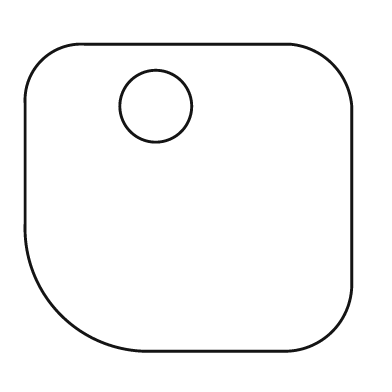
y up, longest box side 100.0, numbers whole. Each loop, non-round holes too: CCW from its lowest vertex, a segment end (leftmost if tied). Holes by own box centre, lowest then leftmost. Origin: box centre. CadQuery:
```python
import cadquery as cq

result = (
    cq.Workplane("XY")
    .moveTo(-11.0, -47.0)
    .lineTo(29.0, -47.0)
    .threePointArc((44.0, -41.0), (50.0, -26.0))
    .lineTo(50.0, 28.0)
    .threePointArc((44.0, 41.0), (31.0, 47.0))
    .lineTo(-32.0, 47.0)
    .threePointArc((-45.0, 42.0), (-50.0, 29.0))
    .lineTo(-50.0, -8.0)
    .threePointArc((-39.0, -36.0), (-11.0, -47.0))
    .close()
    .moveTo(-10.0, 28.0)
    .circle(11.0)
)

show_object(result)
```